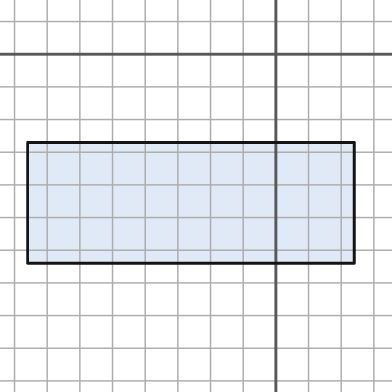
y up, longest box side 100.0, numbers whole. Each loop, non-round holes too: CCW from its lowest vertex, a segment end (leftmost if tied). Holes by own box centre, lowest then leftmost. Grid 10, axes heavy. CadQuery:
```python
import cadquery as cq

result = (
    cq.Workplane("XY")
    .moveTo(-76.0, -64.0)
    .lineTo(24.0, -64.0)
    .lineTo(24.0, -27.0)
    .lineTo(-76.0, -27.0)
    .close()
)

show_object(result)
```